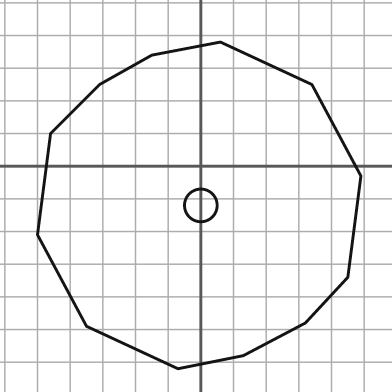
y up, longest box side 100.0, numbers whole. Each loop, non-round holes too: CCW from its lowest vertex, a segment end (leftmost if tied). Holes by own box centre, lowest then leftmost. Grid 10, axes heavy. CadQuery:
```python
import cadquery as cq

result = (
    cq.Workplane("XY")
    .moveTo(-7.0, -62.0)
    .lineTo(13.0, -58.0)
    .lineTo(32.0, -48.0)
    .lineTo(45.0, -34.0)
    .lineTo(49.0, -3.0)
    .lineTo(34.0, 25.0)
    .lineTo(6.0, 38.0)
    .lineTo(-15.0, 34.0)
    .lineTo(-31.0, 25.0)
    .lineTo(-46.0, 10.0)
    .lineTo(-50.0, -21.0)
    .lineTo(-35.0, -49.0)
    .close()
    .moveTo(0.0, -12.0)
    .circle(5.0)
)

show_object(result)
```